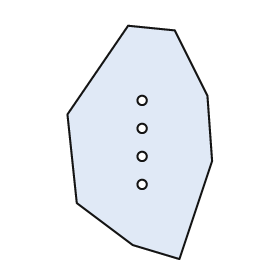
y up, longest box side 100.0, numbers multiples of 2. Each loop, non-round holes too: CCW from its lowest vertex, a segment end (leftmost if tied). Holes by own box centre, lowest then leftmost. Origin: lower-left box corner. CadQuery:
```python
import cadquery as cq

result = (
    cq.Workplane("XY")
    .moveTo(48.0, 0.0)
    .lineTo(62.0, 42.0)
    .lineTo(60.0, 70.0)
    .lineTo(46.0, 98.0)
    .lineTo(26.0, 100.0)
    .lineTo(0.0, 62.0)
    .lineTo(4.0, 24.0)
    .lineTo(28.0, 6.0)
    .close()
    .moveTo(32.0, 32.0)
    .circle(2.0)
    .moveTo(32.0, 44.0)
    .circle(2.0)
    .moveTo(32.0, 56.0)
    .circle(2.0)
    .moveTo(32.0, 68.0)
    .circle(2.0)
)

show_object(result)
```